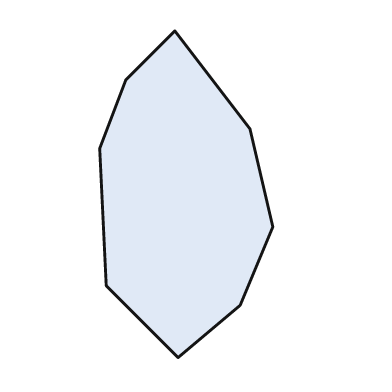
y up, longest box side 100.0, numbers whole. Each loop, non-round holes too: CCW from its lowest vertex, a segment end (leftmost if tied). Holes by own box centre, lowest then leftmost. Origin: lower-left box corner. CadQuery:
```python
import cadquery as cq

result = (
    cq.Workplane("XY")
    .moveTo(24.0, 0.0)
    .lineTo(43.0, 16.0)
    .lineTo(53.0, 40.0)
    .lineTo(46.0, 70.0)
    .lineTo(23.0, 100.0)
    .lineTo(8.0, 85.0)
    .lineTo(0.0, 64.0)
    .lineTo(2.0, 22.0)
    .close()
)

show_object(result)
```